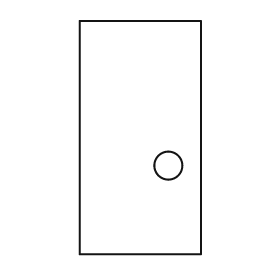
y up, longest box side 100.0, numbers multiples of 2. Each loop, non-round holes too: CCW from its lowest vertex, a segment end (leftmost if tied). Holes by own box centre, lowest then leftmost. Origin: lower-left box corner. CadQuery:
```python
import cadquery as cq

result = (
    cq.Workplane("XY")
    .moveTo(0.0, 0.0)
    .lineTo(52.0, 0.0)
    .lineTo(52.0, 100.0)
    .lineTo(0.0, 100.0)
    .close()
    .moveTo(38.0, 38.0)
    .circle(6.0)
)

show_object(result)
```